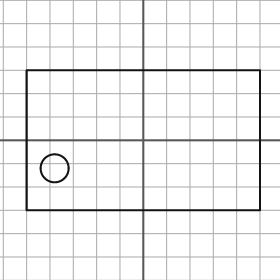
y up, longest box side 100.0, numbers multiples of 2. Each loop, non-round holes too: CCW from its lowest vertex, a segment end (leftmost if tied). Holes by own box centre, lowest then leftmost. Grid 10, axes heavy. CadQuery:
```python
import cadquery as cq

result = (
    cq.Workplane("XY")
    .moveTo(-50.0, -30.0)
    .lineTo(50.0, -30.0)
    .lineTo(50.0, 30.0)
    .lineTo(-50.0, 30.0)
    .close()
    .moveTo(-38.0, -12.0)
    .circle(6.0)
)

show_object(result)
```